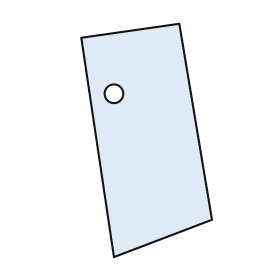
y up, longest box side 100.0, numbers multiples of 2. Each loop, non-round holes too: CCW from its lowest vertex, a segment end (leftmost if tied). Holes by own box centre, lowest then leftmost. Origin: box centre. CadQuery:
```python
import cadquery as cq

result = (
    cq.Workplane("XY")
    .moveTo(-14.0, -50.0)
    .lineTo(28.0, -34.0)
    .lineTo(14.0, 50.0)
    .lineTo(-28.0, 44.0)
    .close()
    .moveTo(-14.0, 20.0)
    .circle(4.0)
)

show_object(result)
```